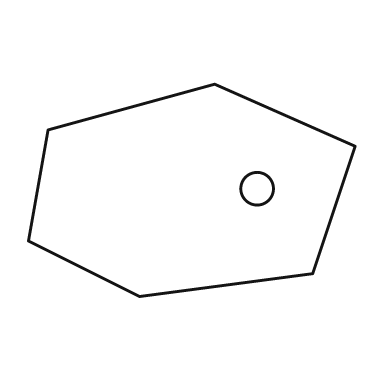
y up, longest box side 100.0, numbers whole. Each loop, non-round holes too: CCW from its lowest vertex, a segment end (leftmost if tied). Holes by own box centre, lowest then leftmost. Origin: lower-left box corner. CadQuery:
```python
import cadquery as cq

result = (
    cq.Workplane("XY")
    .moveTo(34.0, 0.0)
    .lineTo(87.0, 7.0)
    .lineTo(100.0, 46.0)
    .lineTo(57.0, 65.0)
    .lineTo(6.0, 51.0)
    .lineTo(0.0, 17.0)
    .close()
    .moveTo(70.0, 33.0)
    .circle(5.0)
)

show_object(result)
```